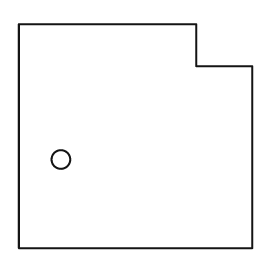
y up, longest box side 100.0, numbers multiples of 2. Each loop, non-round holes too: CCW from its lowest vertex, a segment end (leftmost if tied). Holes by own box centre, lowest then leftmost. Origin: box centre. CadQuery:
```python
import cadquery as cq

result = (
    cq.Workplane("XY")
    .moveTo(-50.0, -48.0)
    .lineTo(50.0, -48.0)
    .lineTo(50.0, 30.0)
    .lineTo(26.0, 30.0)
    .lineTo(26.0, 48.0)
    .lineTo(-50.0, 48.0)
    .close()
    .moveTo(-32.0, -10.0)
    .circle(4.0)
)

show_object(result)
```